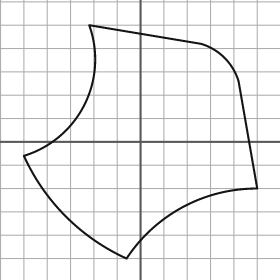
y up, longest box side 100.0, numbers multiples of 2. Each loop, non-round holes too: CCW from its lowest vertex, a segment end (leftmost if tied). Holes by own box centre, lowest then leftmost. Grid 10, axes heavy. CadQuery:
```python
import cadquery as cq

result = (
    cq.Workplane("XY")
    .moveTo(-6.0, -50.0)
    .threePointArc((18.0, -28.0), (50.0, -20.0))
    .lineTo(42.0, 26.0)
    .threePointArc((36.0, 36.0), (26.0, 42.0))
    .lineTo(-22.0, 50.0)
    .threePointArc((-24.0, 16.0), (-50.0, -6.0))
    .threePointArc((-32.0, -32.0), (-6.0, -50.0))
    .close()
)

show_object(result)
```